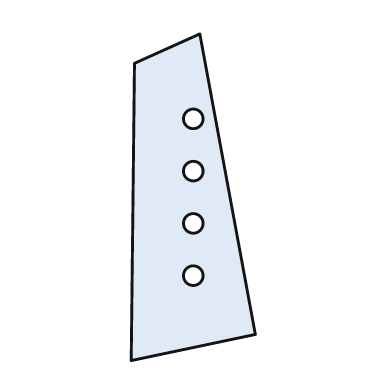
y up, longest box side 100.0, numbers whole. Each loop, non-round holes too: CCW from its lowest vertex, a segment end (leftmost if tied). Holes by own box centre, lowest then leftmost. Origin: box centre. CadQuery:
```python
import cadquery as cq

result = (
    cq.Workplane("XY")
    .moveTo(-19.0, -50.0)
    .lineTo(19.0, -42.0)
    .lineTo(2.0, 50.0)
    .lineTo(-18.0, 41.0)
    .close()
    .moveTo(0.0, -24.0)
    .circle(3.0)
    .moveTo(0.0, -8.0)
    .circle(3.0)
    .moveTo(0.0, 8.0)
    .circle(3.0)
    .moveTo(0.0, 24.0)
    .circle(3.0)
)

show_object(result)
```